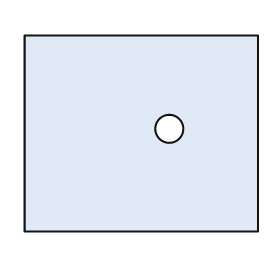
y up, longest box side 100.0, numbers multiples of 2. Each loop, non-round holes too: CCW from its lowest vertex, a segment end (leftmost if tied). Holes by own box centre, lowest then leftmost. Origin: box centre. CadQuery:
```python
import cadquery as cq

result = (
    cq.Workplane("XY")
    .moveTo(-50.0, -42.0)
    .lineTo(50.0, -42.0)
    .lineTo(50.0, 42.0)
    .lineTo(-50.0, 42.0)
    .close()
    .moveTo(12.0, 2.0)
    .circle(6.0)
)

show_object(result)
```